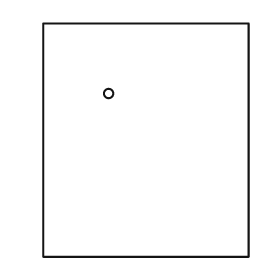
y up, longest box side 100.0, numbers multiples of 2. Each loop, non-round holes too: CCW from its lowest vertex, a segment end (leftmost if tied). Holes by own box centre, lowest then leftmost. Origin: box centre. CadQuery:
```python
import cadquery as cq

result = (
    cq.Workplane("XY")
    .moveTo(-44.0, -50.0)
    .lineTo(44.0, -50.0)
    .lineTo(44.0, 50.0)
    .lineTo(-44.0, 50.0)
    .close()
    .moveTo(-16.0, 20.0)
    .circle(2.0)
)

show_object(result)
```